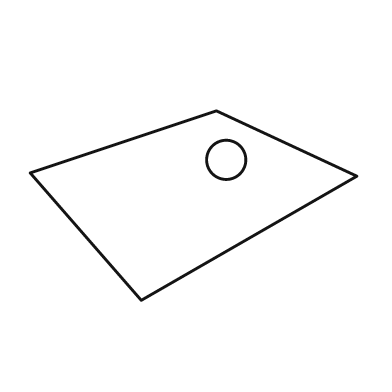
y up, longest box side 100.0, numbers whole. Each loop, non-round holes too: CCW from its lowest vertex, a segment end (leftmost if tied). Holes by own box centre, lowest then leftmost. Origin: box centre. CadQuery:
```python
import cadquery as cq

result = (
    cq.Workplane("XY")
    .moveTo(-16.0, -29.0)
    .lineTo(50.0, 9.0)
    .lineTo(7.0, 29.0)
    .lineTo(-50.0, 10.0)
    .close()
    .moveTo(10.0, 14.0)
    .circle(6.0)
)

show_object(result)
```